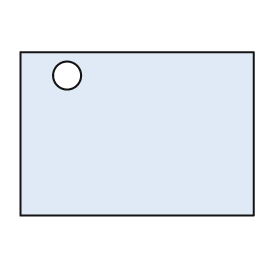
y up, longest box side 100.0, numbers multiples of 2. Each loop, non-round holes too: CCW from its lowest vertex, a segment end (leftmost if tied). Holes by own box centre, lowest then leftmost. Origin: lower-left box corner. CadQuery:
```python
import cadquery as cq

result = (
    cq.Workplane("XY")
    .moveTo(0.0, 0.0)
    .lineTo(100.0, 0.0)
    .lineTo(100.0, 70.0)
    .lineTo(0.0, 70.0)
    .close()
    .moveTo(20.0, 60.0)
    .circle(6.0)
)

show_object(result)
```